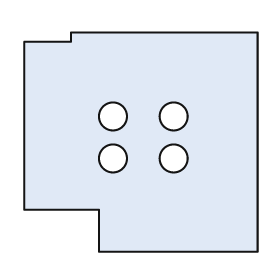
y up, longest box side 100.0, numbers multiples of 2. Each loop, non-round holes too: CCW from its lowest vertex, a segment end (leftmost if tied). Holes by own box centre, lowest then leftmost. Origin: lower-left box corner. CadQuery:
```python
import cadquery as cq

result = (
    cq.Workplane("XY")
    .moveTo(32.0, 0.0)
    .lineTo(100.0, 0.0)
    .lineTo(100.0, 94.0)
    .lineTo(20.0, 94.0)
    .lineTo(20.0, 90.0)
    .lineTo(0.0, 90.0)
    .lineTo(0.0, 18.0)
    .lineTo(32.0, 18.0)
    .close()
    .moveTo(38.0, 40.0)
    .circle(6.0)
    .moveTo(64.0, 40.0)
    .circle(6.0)
    .moveTo(38.0, 58.0)
    .circle(6.0)
    .moveTo(64.0, 58.0)
    .circle(6.0)
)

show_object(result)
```